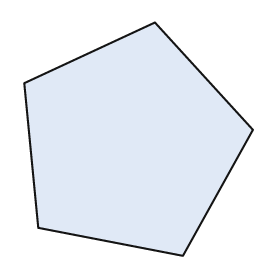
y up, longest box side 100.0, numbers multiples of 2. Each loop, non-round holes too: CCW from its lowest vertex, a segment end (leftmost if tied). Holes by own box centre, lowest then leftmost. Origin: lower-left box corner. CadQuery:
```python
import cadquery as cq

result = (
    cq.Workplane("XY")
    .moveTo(68.0, 0.0)
    .lineTo(98.0, 54.0)
    .lineTo(56.0, 100.0)
    .lineTo(0.0, 74.0)
    .lineTo(6.0, 12.0)
    .close()
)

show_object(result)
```